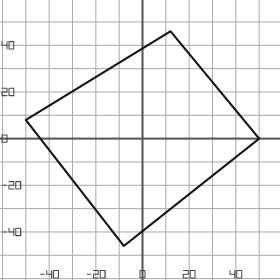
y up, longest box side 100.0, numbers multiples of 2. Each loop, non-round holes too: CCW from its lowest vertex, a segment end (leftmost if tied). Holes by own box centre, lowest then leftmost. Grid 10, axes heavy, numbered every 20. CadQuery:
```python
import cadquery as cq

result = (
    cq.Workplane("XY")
    .moveTo(-8.0, -46.0)
    .lineTo(50.0, 0.0)
    .lineTo(12.0, 46.0)
    .lineTo(-50.0, 8.0)
    .close()
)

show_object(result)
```